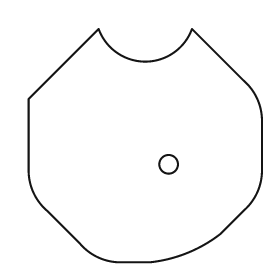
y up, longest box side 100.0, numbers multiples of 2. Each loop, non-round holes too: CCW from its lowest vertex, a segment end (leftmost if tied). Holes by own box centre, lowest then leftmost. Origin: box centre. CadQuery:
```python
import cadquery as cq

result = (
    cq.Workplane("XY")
    .moveTo(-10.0, -50.0)
    .lineTo(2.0, -50.0)
    .threePointArc((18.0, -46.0), (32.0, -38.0))
    .lineTo(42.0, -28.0)
    .threePointArc((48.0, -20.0), (50.0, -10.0))
    .lineTo(50.0, 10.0)
    .threePointArc((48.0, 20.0), (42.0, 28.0))
    .lineTo(20.0, 50.0)
    .threePointArc((0.0, 36.0), (-20.0, 50.0))
    .lineTo(-50.0, 20.0)
    .lineTo(-50.0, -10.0)
    .threePointArc((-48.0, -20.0), (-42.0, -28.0))
    .lineTo(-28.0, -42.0)
    .threePointArc((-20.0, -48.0), (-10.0, -50.0))
    .close()
    .moveTo(10.0, -8.0)
    .circle(4.0)
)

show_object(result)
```